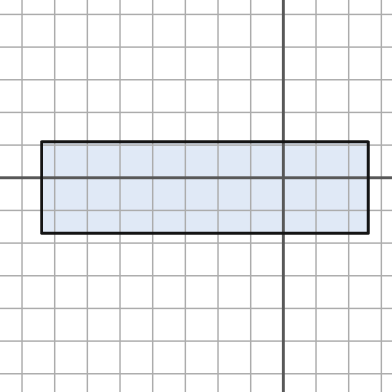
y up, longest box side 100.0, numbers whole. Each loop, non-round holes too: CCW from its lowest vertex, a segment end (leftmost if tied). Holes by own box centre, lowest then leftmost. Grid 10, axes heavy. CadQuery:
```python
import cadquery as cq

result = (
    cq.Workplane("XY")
    .moveTo(-74.0, -17.0)
    .lineTo(26.0, -17.0)
    .lineTo(26.0, 11.0)
    .lineTo(-74.0, 11.0)
    .close()
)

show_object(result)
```